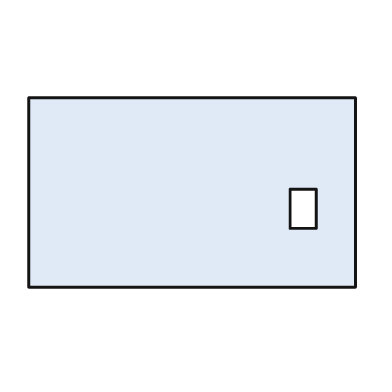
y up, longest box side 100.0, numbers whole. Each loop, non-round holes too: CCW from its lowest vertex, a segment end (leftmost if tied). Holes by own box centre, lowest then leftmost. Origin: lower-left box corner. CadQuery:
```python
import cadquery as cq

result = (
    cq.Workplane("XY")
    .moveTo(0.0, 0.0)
    .lineTo(100.0, 0.0)
    .lineTo(100.0, 58.0)
    .lineTo(0.0, 58.0)
    .close()
    .moveTo(80.0, 18.0)
    .lineTo(88.0, 18.0)
    .lineTo(88.0, 30.0)
    .lineTo(80.0, 30.0)
    .close()
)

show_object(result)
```